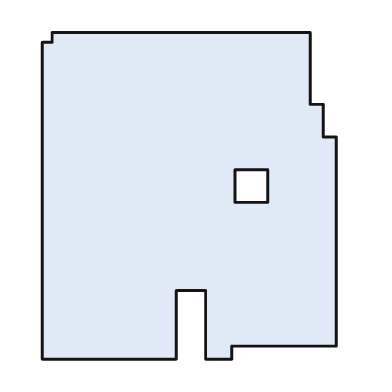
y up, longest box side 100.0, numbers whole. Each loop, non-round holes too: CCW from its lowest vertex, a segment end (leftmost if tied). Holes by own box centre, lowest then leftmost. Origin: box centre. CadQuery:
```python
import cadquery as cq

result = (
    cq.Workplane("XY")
    .moveTo(-45.0, -50.0)
    .lineTo(-4.0, -50.0)
    .lineTo(-4.0, -29.0)
    .lineTo(5.0, -29.0)
    .lineTo(5.0, -50.0)
    .lineTo(13.0, -50.0)
    .lineTo(13.0, -46.0)
    .lineTo(45.0, -46.0)
    .lineTo(45.0, 18.0)
    .lineTo(41.0, 18.0)
    .lineTo(41.0, 28.0)
    .lineTo(37.0, 28.0)
    .lineTo(37.0, 50.0)
    .lineTo(-42.0, 50.0)
    .lineTo(-42.0, 47.0)
    .lineTo(-45.0, 47.0)
    .close()
    .moveTo(14.0, -2.0)
    .lineTo(24.0, -2.0)
    .lineTo(24.0, 8.0)
    .lineTo(14.0, 8.0)
    .close()
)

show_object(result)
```